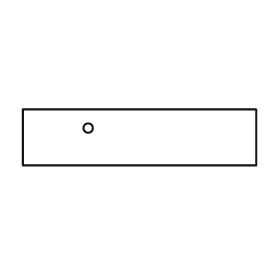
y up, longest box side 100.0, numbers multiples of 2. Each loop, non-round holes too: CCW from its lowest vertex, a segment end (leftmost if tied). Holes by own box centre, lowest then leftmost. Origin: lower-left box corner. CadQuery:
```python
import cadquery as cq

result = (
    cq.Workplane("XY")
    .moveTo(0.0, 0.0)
    .lineTo(100.0, 0.0)
    .lineTo(100.0, 24.0)
    .lineTo(0.0, 24.0)
    .close()
    .moveTo(28.0, 16.0)
    .circle(2.0)
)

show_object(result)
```